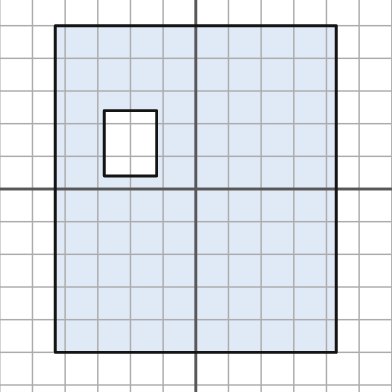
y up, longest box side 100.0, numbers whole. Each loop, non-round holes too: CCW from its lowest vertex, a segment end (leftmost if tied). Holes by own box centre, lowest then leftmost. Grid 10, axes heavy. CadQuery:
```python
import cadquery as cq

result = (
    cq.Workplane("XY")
    .moveTo(-43.0, -50.0)
    .lineTo(43.0, -50.0)
    .lineTo(43.0, 50.0)
    .lineTo(-43.0, 50.0)
    .close()
    .moveTo(-28.0, 4.0)
    .lineTo(-12.0, 4.0)
    .lineTo(-12.0, 24.0)
    .lineTo(-28.0, 24.0)
    .close()
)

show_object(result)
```